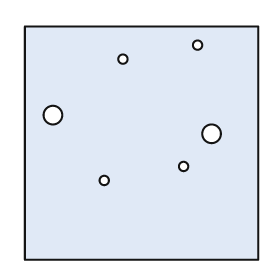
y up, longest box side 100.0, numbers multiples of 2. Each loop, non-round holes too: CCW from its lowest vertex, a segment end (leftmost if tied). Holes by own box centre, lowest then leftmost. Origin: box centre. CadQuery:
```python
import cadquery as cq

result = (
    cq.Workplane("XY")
    .moveTo(-50.0, -50.0)
    .lineTo(50.0, -50.0)
    .lineTo(50.0, 50.0)
    .lineTo(-50.0, 50.0)
    .close()
    .moveTo(-16.0, -16.0)
    .circle(2.0)
    .moveTo(18.0, -10.0)
    .circle(2.0)
    .moveTo(30.0, 4.0)
    .circle(4.0)
    .moveTo(-38.0, 12.0)
    .circle(4.0)
    .moveTo(-8.0, 36.0)
    .circle(2.0)
    .moveTo(24.0, 42.0)
    .circle(2.0)
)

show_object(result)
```